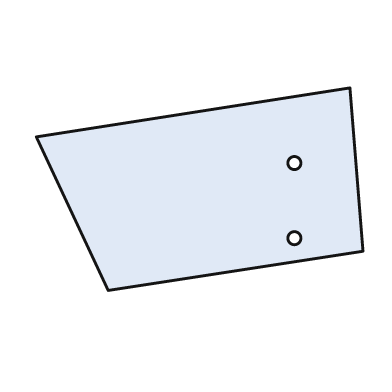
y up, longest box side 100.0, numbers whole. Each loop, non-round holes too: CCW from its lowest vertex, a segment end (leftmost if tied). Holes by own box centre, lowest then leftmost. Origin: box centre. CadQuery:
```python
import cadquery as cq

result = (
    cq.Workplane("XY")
    .moveTo(-28.0, -31.0)
    .lineTo(50.0, -19.0)
    .lineTo(46.0, 31.0)
    .lineTo(-50.0, 16.0)
    .close()
    .moveTo(29.0, -15.0)
    .circle(2.0)
    .moveTo(29.0, 8.0)
    .circle(2.0)
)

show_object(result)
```